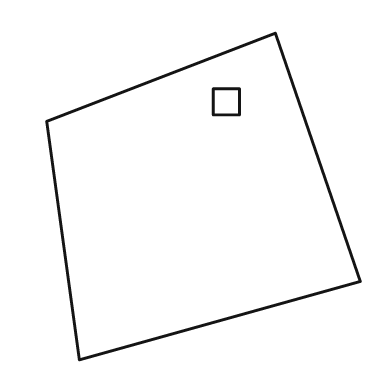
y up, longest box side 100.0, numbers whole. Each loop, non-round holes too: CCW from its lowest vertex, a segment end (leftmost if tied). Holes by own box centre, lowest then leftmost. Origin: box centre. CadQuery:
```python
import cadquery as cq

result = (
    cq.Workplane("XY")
    .moveTo(-38.0, -50.0)
    .lineTo(48.0, -26.0)
    .lineTo(22.0, 50.0)
    .lineTo(-48.0, 23.0)
    .close()
    .moveTo(3.0, 25.0)
    .lineTo(11.0, 25.0)
    .lineTo(11.0, 33.0)
    .lineTo(3.0, 33.0)
    .close()
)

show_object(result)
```